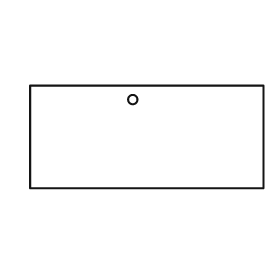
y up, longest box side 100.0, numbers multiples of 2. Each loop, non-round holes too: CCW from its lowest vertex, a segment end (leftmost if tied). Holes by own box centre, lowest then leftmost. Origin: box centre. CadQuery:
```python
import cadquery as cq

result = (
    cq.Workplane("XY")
    .moveTo(-50.0, -22.0)
    .lineTo(50.0, -22.0)
    .lineTo(50.0, 22.0)
    .lineTo(-50.0, 22.0)
    .close()
    .moveTo(-6.0, 16.0)
    .circle(2.0)
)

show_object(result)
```